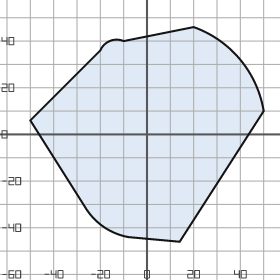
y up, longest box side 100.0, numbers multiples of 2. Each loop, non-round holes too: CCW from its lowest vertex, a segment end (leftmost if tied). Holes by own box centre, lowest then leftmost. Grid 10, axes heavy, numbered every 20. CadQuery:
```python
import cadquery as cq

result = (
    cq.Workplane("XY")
    .moveTo(14.0, -46.0)
    .lineTo(50.0, 10.0)
    .threePointArc((40.0, 32.0), (20.0, 46.0))
    .lineTo(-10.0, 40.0)
    .threePointArc((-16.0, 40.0), (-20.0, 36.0))
    .lineTo(-50.0, 6.0)
    .lineTo(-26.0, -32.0)
    .threePointArc((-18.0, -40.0), (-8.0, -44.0))
    .close()
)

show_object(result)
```